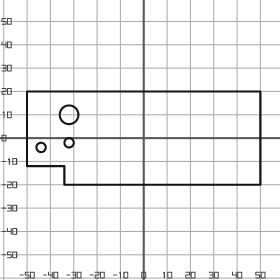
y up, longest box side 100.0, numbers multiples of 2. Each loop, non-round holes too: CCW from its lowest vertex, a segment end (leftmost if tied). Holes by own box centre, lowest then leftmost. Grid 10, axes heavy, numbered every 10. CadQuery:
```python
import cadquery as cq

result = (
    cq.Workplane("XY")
    .moveTo(-34.0, -20.0)
    .lineTo(50.0, -20.0)
    .lineTo(50.0, 20.0)
    .lineTo(-50.0, 20.0)
    .lineTo(-50.0, -12.0)
    .lineTo(-34.0, -12.0)
    .close()
    .moveTo(-44.0, -4.0)
    .circle(2.0)
    .moveTo(-32.0, -2.0)
    .circle(2.0)
    .moveTo(-32.0, 10.0)
    .circle(4.0)
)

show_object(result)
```